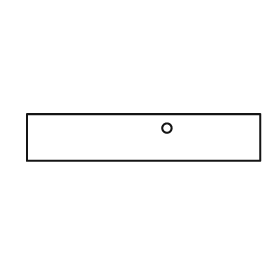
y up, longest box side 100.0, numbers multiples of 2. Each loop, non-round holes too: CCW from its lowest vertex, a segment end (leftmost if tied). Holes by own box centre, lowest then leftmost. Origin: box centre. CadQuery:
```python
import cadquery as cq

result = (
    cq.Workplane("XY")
    .moveTo(-50.0, -10.0)
    .lineTo(50.0, -10.0)
    .lineTo(50.0, 10.0)
    .lineTo(-50.0, 10.0)
    .close()
    .moveTo(10.0, 4.0)
    .circle(2.0)
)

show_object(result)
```